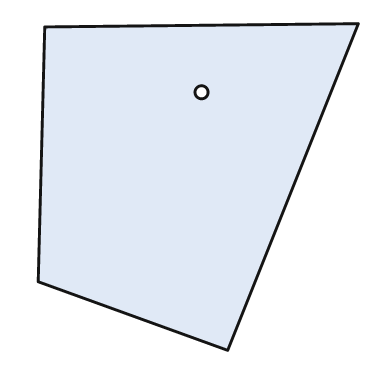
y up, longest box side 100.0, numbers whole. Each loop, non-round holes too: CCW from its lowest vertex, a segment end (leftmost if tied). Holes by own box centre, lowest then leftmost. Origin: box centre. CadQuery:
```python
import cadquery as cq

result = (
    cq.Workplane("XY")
    .moveTo(9.0, -50.0)
    .lineTo(49.0, 50.0)
    .lineTo(-47.0, 49.0)
    .lineTo(-49.0, -29.0)
    .close()
    .moveTo(1.0, 29.0)
    .circle(2.0)
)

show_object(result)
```